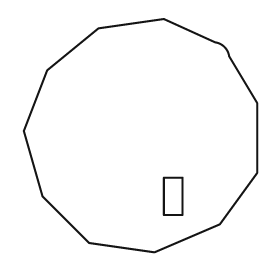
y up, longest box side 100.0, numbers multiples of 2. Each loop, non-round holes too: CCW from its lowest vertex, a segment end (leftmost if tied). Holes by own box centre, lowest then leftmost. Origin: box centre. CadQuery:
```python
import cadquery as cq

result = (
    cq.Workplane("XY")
    .moveTo(6.0, -50.0)
    .lineTo(34.0, -38.0)
    .lineTo(50.0, -16.0)
    .lineTo(50.0, 14.0)
    .lineTo(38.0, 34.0)
    .threePointArc((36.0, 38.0), (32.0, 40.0))
    .lineTo(10.0, 50.0)
    .lineTo(-18.0, 46.0)
    .lineTo(-40.0, 28.0)
    .lineTo(-50.0, 2.0)
    .lineTo(-42.0, -26.0)
    .lineTo(-22.0, -46.0)
    .close()
    .moveTo(10.0, -34.0)
    .lineTo(18.0, -34.0)
    .lineTo(18.0, -18.0)
    .lineTo(10.0, -18.0)
    .close()
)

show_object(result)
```